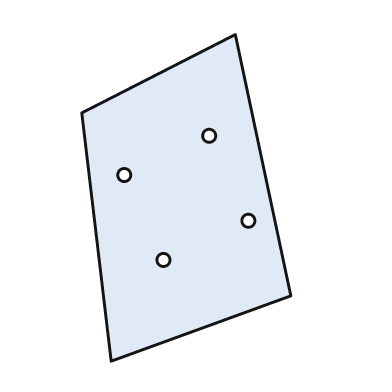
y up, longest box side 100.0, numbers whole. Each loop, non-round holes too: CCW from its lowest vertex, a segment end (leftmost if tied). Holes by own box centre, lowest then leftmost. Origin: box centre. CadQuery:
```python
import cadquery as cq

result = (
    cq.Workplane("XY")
    .moveTo(-23.0, -50.0)
    .lineTo(32.0, -30.0)
    .lineTo(15.0, 50.0)
    .lineTo(-32.0, 26.0)
    .close()
    .moveTo(-7.0, -19.0)
    .circle(2.0)
    .moveTo(19.0, -7.0)
    .circle(2.0)
    .moveTo(-19.0, 7.0)
    .circle(2.0)
    .moveTo(7.0, 19.0)
    .circle(2.0)
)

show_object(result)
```